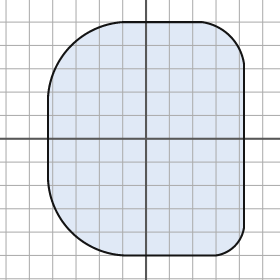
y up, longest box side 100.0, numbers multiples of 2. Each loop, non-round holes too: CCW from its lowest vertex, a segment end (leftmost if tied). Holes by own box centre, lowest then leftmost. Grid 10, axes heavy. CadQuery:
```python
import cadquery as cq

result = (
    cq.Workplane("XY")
    .moveTo(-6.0, -50.0)
    .lineTo(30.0, -50.0)
    .threePointArc((38.0, -46.0), (42.0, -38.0))
    .lineTo(42.0, 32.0)
    .threePointArc((36.0, 44.0), (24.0, 50.0))
    .lineTo(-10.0, 50.0)
    .threePointArc((-32.0, 40.0), (-42.0, 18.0))
    .lineTo(-42.0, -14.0)
    .threePointArc((-32.0, -40.0), (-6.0, -50.0))
    .close()
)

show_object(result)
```